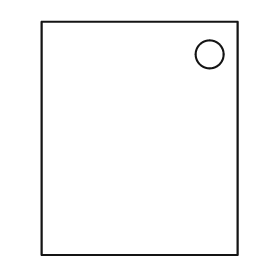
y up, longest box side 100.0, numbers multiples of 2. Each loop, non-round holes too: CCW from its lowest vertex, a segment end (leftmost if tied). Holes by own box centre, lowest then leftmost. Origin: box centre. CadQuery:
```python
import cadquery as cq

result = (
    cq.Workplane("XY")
    .moveTo(-42.0, -50.0)
    .lineTo(42.0, -50.0)
    .lineTo(42.0, 50.0)
    .lineTo(-42.0, 50.0)
    .close()
    .moveTo(30.0, 36.0)
    .circle(6.0)
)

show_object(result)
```